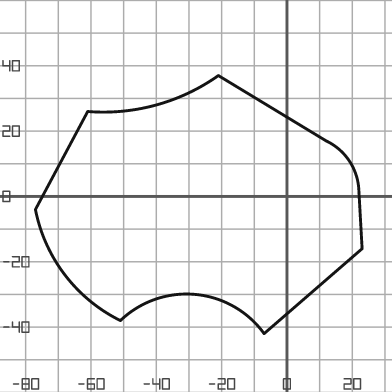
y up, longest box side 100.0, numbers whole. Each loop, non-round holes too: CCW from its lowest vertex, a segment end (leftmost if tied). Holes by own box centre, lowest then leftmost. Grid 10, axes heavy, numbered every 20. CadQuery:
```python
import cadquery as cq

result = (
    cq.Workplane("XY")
    .moveTo(-7.0, -42.0)
    .lineTo(23.0, -16.0)
    .lineTo(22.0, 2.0)
    .threePointArc((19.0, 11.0), (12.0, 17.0))
    .lineTo(-21.0, 37.0)
    .threePointArc((-40.0, 28.0), (-61.0, 26.0))
    .lineTo(-77.0, -4.0)
    .threePointArc((-68.0, -24.0), (-51.0, -38.0))
    .threePointArc((-28.0, -30.0), (-7.0, -42.0))
    .close()
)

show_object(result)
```